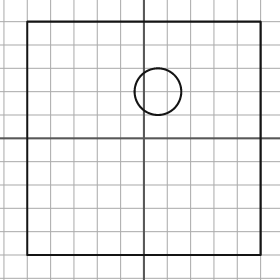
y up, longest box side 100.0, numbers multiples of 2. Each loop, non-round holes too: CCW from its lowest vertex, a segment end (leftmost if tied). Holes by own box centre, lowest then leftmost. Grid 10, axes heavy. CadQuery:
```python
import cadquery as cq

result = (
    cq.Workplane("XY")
    .moveTo(-50.0, -50.0)
    .lineTo(50.0, -50.0)
    .lineTo(50.0, 50.0)
    .lineTo(-50.0, 50.0)
    .close()
    .moveTo(6.0, 20.0)
    .circle(10.0)
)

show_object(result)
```